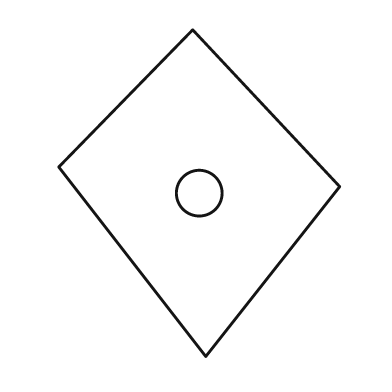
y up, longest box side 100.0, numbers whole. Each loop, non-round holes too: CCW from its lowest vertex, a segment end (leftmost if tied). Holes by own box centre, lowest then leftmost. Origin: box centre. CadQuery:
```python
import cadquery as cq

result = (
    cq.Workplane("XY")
    .moveTo(2.0, -50.0)
    .lineTo(43.0, 2.0)
    .lineTo(-2.0, 50.0)
    .lineTo(-43.0, 8.0)
    .close()
    .moveTo(0.0, 0.0)
    .circle(7.0)
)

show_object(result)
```